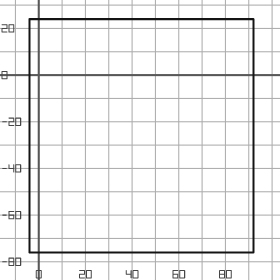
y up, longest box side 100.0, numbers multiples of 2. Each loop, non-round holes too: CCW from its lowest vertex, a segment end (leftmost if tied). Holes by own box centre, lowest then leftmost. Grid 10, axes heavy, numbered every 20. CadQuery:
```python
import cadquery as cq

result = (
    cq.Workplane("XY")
    .moveTo(-4.0, -76.0)
    .lineTo(92.0, -76.0)
    .lineTo(92.0, 24.0)
    .lineTo(-4.0, 24.0)
    .close()
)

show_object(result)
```